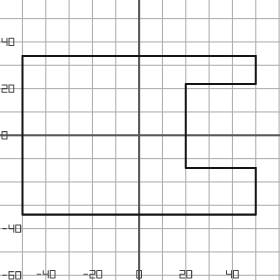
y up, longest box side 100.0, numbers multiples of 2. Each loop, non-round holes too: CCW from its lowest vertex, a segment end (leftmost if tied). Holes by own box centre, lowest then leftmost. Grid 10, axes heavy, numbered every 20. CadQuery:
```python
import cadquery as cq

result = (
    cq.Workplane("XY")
    .moveTo(-50.0, -34.0)
    .lineTo(50.0, -34.0)
    .lineTo(50.0, -14.0)
    .lineTo(20.0, -14.0)
    .lineTo(20.0, 22.0)
    .lineTo(50.0, 22.0)
    .lineTo(50.0, 34.0)
    .lineTo(-50.0, 34.0)
    .close()
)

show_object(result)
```